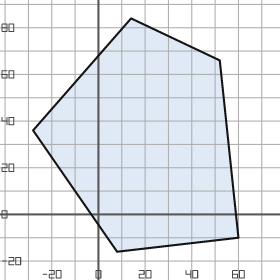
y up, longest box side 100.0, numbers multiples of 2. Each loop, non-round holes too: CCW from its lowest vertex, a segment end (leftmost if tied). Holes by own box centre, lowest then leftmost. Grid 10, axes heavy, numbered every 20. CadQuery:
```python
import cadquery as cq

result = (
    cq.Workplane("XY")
    .moveTo(8.0, -16.0)
    .lineTo(60.0, -10.0)
    .lineTo(52.0, 66.0)
    .lineTo(14.0, 84.0)
    .lineTo(-28.0, 36.0)
    .close()
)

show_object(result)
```